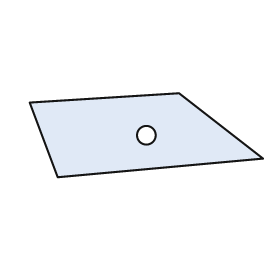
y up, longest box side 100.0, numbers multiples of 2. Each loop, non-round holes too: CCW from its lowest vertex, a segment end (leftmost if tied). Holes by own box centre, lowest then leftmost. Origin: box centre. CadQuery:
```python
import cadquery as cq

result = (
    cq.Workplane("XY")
    .moveTo(-38.0, -18.0)
    .lineTo(50.0, -10.0)
    .lineTo(14.0, 18.0)
    .lineTo(-50.0, 14.0)
    .close()
    .moveTo(0.0, 0.0)
    .circle(4.0)
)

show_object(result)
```